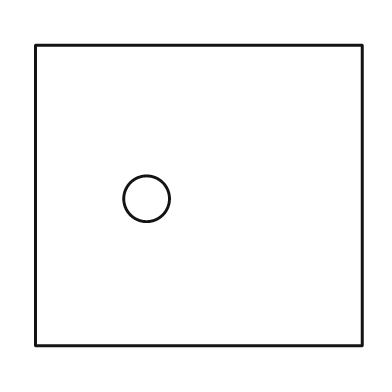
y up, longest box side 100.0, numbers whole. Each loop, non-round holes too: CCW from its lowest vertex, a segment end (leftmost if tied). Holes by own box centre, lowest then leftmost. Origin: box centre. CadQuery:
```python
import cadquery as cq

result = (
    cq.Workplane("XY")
    .moveTo(-50.0, -46.0)
    .lineTo(50.0, -46.0)
    .lineTo(50.0, 46.0)
    .lineTo(-50.0, 46.0)
    .close()
    .moveTo(-16.0, -1.0)
    .circle(7.0)
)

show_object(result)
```